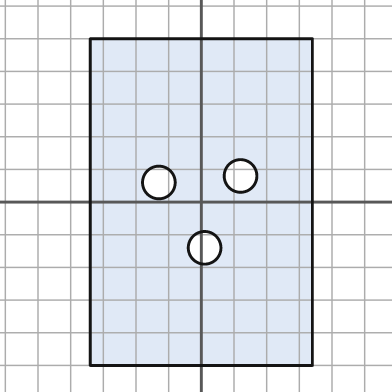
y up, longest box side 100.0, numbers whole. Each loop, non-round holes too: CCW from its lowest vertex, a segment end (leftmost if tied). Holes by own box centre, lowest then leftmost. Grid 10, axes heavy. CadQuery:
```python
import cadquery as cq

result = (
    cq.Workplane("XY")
    .moveTo(-34.0, -50.0)
    .lineTo(34.0, -50.0)
    .lineTo(34.0, 50.0)
    .lineTo(-34.0, 50.0)
    .close()
    .moveTo(1.0, -14.0)
    .circle(5.0)
    .moveTo(-13.0, 6.0)
    .circle(5.0)
    .moveTo(12.0, 8.0)
    .circle(5.0)
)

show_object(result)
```